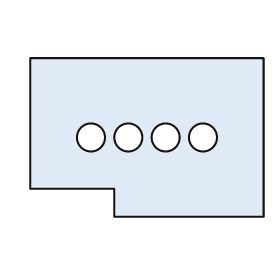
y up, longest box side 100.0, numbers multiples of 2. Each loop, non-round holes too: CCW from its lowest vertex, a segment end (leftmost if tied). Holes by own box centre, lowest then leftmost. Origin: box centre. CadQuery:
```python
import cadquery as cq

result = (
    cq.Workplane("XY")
    .moveTo(-14.0, -34.0)
    .lineTo(50.0, -34.0)
    .lineTo(50.0, 34.0)
    .lineTo(-50.0, 34.0)
    .lineTo(-50.0, -22.0)
    .lineTo(-14.0, -22.0)
    .close()
    .moveTo(-24.0, 0.0)
    .circle(6.0)
    .moveTo(-8.0, 0.0)
    .circle(6.0)
    .moveTo(8.0, 0.0)
    .circle(6.0)
    .moveTo(24.0, 0.0)
    .circle(6.0)
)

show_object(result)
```